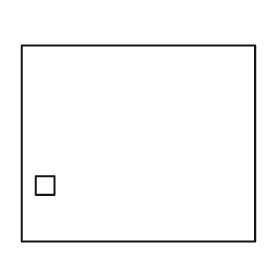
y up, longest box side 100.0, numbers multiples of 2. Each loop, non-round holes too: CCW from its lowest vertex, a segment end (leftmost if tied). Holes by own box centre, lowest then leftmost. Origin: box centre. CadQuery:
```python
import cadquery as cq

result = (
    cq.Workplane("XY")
    .moveTo(-50.0, -42.0)
    .lineTo(50.0, -42.0)
    .lineTo(50.0, 42.0)
    .lineTo(-50.0, 42.0)
    .close()
    .moveTo(-44.0, -22.0)
    .lineTo(-36.0, -22.0)
    .lineTo(-36.0, -14.0)
    .lineTo(-44.0, -14.0)
    .close()
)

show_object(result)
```